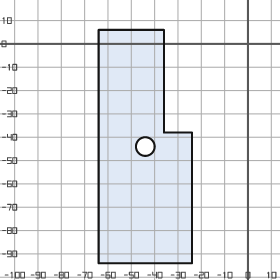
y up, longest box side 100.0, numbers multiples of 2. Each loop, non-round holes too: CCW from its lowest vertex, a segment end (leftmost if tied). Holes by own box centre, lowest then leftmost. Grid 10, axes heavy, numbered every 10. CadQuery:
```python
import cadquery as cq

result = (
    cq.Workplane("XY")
    .moveTo(-64.0, -94.0)
    .lineTo(-24.0, -94.0)
    .lineTo(-24.0, -38.0)
    .lineTo(-36.0, -38.0)
    .lineTo(-36.0, 6.0)
    .lineTo(-64.0, 6.0)
    .close()
    .moveTo(-44.0, -44.0)
    .circle(4.0)
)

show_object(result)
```